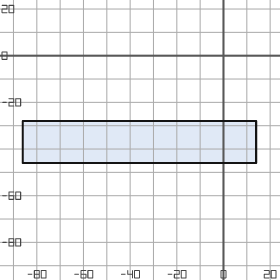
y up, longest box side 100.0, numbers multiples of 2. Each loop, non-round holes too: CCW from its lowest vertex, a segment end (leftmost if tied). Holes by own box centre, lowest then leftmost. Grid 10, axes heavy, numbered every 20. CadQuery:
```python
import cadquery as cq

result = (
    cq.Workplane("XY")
    .moveTo(-86.0, -46.0)
    .lineTo(14.0, -46.0)
    .lineTo(14.0, -28.0)
    .lineTo(-86.0, -28.0)
    .close()
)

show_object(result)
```